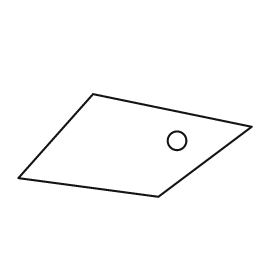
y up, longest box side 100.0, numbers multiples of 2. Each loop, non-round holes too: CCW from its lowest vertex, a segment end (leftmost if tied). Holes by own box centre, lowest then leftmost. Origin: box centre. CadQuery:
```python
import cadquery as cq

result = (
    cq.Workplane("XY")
    .moveTo(10.0, -22.0)
    .lineTo(50.0, 8.0)
    .lineTo(-18.0, 22.0)
    .lineTo(-50.0, -14.0)
    .close()
    .moveTo(18.0, 2.0)
    .circle(4.0)
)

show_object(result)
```